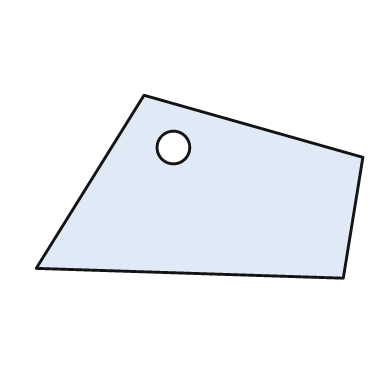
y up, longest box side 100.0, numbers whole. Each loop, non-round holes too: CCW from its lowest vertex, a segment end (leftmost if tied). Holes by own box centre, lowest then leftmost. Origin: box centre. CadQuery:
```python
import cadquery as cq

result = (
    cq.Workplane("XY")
    .moveTo(44.0, -28.0)
    .lineTo(50.0, 9.0)
    .lineTo(-17.0, 28.0)
    .lineTo(-50.0, -25.0)
    .close()
    .moveTo(-8.0, 12.0)
    .circle(5.0)
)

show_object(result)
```